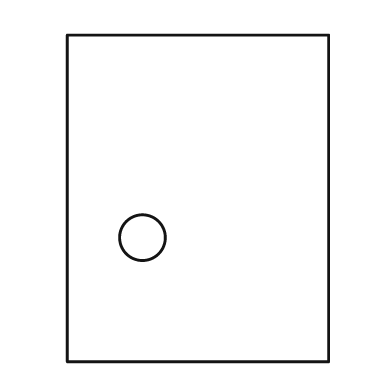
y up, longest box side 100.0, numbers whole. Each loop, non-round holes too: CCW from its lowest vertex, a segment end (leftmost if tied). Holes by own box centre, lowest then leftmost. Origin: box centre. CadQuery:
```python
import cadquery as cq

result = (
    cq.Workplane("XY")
    .moveTo(-40.0, -50.0)
    .lineTo(40.0, -50.0)
    .lineTo(40.0, 50.0)
    .lineTo(-40.0, 50.0)
    .close()
    .moveTo(-17.0, -12.0)
    .circle(7.0)
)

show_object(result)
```